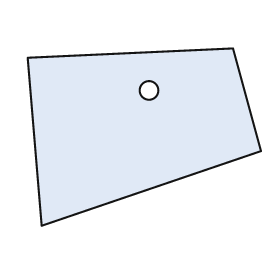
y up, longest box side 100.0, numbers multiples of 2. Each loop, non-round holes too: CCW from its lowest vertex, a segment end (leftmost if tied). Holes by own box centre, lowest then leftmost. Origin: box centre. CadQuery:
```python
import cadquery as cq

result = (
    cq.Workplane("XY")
    .moveTo(-44.0, -38.0)
    .lineTo(50.0, -6.0)
    .lineTo(38.0, 38.0)
    .lineTo(-50.0, 34.0)
    .close()
    .moveTo(2.0, 20.0)
    .circle(4.0)
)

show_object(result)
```